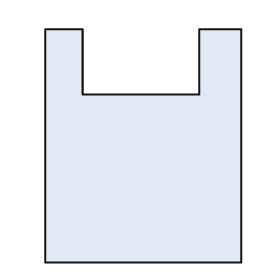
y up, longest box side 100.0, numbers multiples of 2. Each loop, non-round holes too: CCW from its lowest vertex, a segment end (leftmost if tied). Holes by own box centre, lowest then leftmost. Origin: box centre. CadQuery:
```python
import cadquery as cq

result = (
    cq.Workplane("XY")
    .moveTo(-42.0, -50.0)
    .lineTo(42.0, -50.0)
    .lineTo(42.0, 50.0)
    .lineTo(24.0, 50.0)
    .lineTo(24.0, 22.0)
    .lineTo(-26.0, 22.0)
    .lineTo(-26.0, 50.0)
    .lineTo(-42.0, 50.0)
    .close()
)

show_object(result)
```